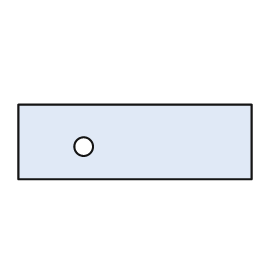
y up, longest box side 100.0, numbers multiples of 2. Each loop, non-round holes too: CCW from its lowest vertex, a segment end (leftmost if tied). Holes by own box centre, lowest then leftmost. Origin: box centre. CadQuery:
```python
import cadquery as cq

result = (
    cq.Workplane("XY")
    .moveTo(-50.0, -16.0)
    .lineTo(50.0, -16.0)
    .lineTo(50.0, 16.0)
    .lineTo(-50.0, 16.0)
    .close()
    .moveTo(-22.0, -2.0)
    .circle(4.0)
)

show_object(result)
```